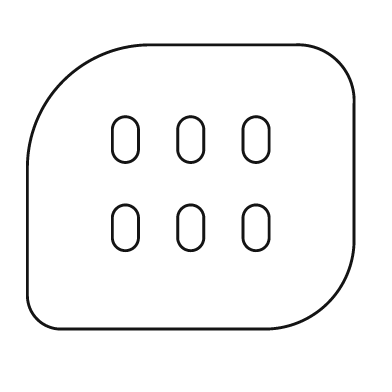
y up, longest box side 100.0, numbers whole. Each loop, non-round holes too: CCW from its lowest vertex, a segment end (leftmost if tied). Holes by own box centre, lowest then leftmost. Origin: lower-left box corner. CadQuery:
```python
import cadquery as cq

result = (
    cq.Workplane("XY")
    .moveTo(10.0, 0.0)
    .lineTo(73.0, 0.0)
    .threePointArc((92.0, 8.0), (100.0, 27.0))
    .lineTo(100.0, 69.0)
    .threePointArc((95.0, 82.0), (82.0, 87.0))
    .lineTo(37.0, 87.0)
    .threePointArc((11.0, 76.0), (0.0, 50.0))
    .lineTo(0.0, 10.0)
    .threePointArc((3.0, 3.0), (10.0, 0.0))
    .close()
    .moveTo(26.0, 28.0)
    .threePointArc((30.0, 24.0), (34.0, 28.0))
    .lineTo(34.0, 34.0)
    .threePointArc((30.0, 38.0), (26.0, 34.0))
    .close()
    .moveTo(46.0, 28.0)
    .threePointArc((50.0, 24.0), (54.0, 28.0))
    .lineTo(54.0, 34.0)
    .threePointArc((50.0, 38.0), (46.0, 34.0))
    .close()
    .moveTo(66.0, 28.0)
    .threePointArc((70.0, 24.0), (74.0, 28.0))
    .lineTo(74.0, 34.0)
    .threePointArc((70.0, 38.0), (66.0, 34.0))
    .close()
    .moveTo(26.0, 55.0)
    .threePointArc((30.0, 51.0), (34.0, 55.0))
    .lineTo(34.0, 61.0)
    .threePointArc((30.0, 65.0), (26.0, 61.0))
    .close()
    .moveTo(46.0, 55.0)
    .threePointArc((50.0, 51.0), (54.0, 55.0))
    .lineTo(54.0, 61.0)
    .threePointArc((50.0, 65.0), (46.0, 61.0))
    .close()
    .moveTo(66.0, 55.0)
    .threePointArc((70.0, 51.0), (74.0, 55.0))
    .lineTo(74.0, 61.0)
    .threePointArc((70.0, 65.0), (66.0, 61.0))
    .close()
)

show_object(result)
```